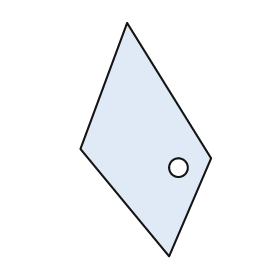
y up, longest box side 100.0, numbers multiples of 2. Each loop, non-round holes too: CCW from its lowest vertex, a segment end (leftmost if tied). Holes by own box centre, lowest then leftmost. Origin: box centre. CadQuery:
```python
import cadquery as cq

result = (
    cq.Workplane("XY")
    .moveTo(10.0, -50.0)
    .lineTo(28.0, -8.0)
    .lineTo(-8.0, 50.0)
    .lineTo(-28.0, -4.0)
    .close()
    .moveTo(14.0, -12.0)
    .circle(4.0)
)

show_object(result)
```